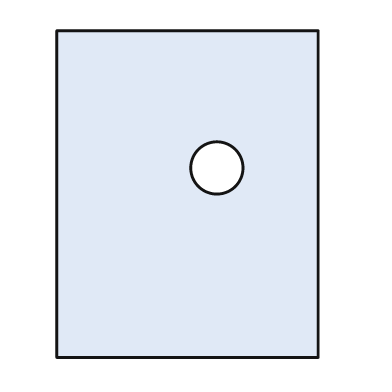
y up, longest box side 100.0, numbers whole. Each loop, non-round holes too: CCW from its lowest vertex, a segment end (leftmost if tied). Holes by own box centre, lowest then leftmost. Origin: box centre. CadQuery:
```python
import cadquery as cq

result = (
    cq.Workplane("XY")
    .moveTo(-40.0, -50.0)
    .lineTo(40.0, -50.0)
    .lineTo(40.0, 50.0)
    .lineTo(-40.0, 50.0)
    .close()
    .moveTo(9.0, 8.0)
    .circle(8.0)
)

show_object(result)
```